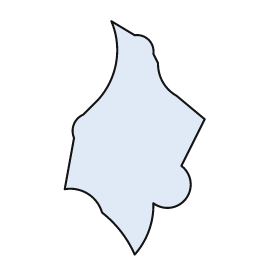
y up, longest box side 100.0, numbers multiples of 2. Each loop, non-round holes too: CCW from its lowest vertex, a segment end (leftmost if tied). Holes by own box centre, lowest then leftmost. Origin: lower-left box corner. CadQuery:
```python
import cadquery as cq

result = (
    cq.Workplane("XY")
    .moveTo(30.0, 0.0)
    .threePointArc((36.0, 10.0), (38.0, 22.0))
    .threePointArc((52.0, 24.0), (50.0, 38.0))
    .lineTo(60.0, 58.0)
    .lineTo(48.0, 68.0)
    .threePointArc((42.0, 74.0), (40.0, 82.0))
    .lineTo(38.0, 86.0)
    .threePointArc((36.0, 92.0), (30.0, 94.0))
    .lineTo(20.0, 100.0)
    .threePointArc((22.0, 82.0), (14.0, 66.0))
    .lineTo(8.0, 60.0)
    .threePointArc((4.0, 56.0), (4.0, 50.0))
    .lineTo(0.0, 28.0)
    .threePointArc((10.0, 26.0), (16.0, 18.0))
    .threePointArc((24.0, 10.0), (30.0, 0.0))
    .close()
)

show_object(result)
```